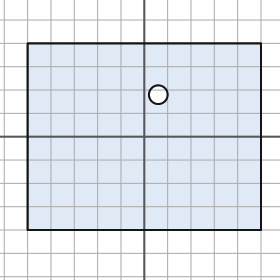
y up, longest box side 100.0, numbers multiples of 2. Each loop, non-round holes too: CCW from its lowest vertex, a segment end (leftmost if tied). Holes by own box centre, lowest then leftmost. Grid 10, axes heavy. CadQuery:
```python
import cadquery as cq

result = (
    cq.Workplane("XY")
    .moveTo(-50.0, -40.0)
    .lineTo(50.0, -40.0)
    .lineTo(50.0, 40.0)
    .lineTo(-50.0, 40.0)
    .close()
    .moveTo(6.0, 18.0)
    .circle(4.0)
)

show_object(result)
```